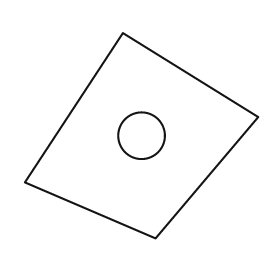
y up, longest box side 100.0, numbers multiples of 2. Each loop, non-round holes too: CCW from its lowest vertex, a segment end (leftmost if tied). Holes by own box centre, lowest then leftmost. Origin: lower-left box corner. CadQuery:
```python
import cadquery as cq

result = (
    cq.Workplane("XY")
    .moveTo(56.0, 0.0)
    .lineTo(100.0, 52.0)
    .lineTo(42.0, 88.0)
    .lineTo(0.0, 24.0)
    .close()
    .moveTo(50.0, 44.0)
    .circle(10.0)
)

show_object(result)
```